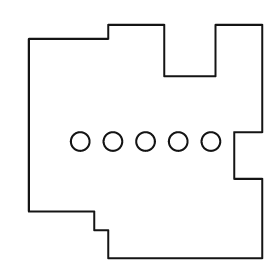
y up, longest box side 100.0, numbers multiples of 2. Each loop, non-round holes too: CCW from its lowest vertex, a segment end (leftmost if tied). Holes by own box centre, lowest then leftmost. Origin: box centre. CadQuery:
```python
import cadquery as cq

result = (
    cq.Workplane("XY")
    .moveTo(-16.0, -50.0)
    .lineTo(50.0, -50.0)
    .lineTo(50.0, -16.0)
    .lineTo(38.0, -16.0)
    .lineTo(38.0, 4.0)
    .lineTo(50.0, 4.0)
    .lineTo(50.0, 50.0)
    .lineTo(30.0, 50.0)
    .lineTo(30.0, 28.0)
    .lineTo(8.0, 28.0)
    .lineTo(8.0, 50.0)
    .lineTo(-16.0, 50.0)
    .lineTo(-16.0, 44.0)
    .lineTo(-50.0, 44.0)
    .lineTo(-50.0, -30.0)
    .lineTo(-22.0, -30.0)
    .lineTo(-22.0, -38.0)
    .lineTo(-16.0, -38.0)
    .close()
    .moveTo(-28.0, 0.0)
    .circle(4.0)
    .moveTo(-14.0, 0.0)
    .circle(4.0)
    .moveTo(0.0, 0.0)
    .circle(4.0)
    .moveTo(14.0, 0.0)
    .circle(4.0)
    .moveTo(28.0, 0.0)
    .circle(4.0)
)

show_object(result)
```